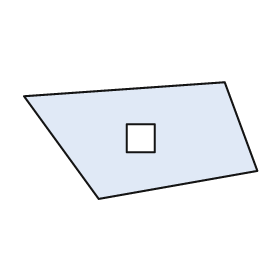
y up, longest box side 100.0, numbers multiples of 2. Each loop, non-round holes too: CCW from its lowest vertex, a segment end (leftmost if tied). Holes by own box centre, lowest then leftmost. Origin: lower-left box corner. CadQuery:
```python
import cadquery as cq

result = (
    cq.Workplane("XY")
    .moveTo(32.0, 0.0)
    .lineTo(100.0, 12.0)
    .lineTo(86.0, 50.0)
    .lineTo(0.0, 44.0)
    .close()
    .moveTo(44.0, 20.0)
    .lineTo(56.0, 20.0)
    .lineTo(56.0, 32.0)
    .lineTo(44.0, 32.0)
    .close()
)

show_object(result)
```